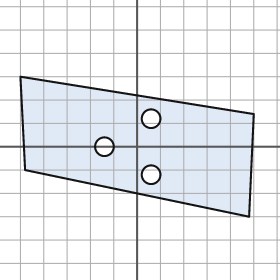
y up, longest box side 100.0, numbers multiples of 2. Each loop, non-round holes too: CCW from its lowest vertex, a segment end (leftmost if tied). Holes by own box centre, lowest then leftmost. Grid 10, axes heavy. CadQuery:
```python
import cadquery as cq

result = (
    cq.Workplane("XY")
    .moveTo(48.0, -30.0)
    .lineTo(50.0, 14.0)
    .lineTo(-50.0, 30.0)
    .lineTo(-48.0, -10.0)
    .close()
    .moveTo(6.0, -12.0)
    .circle(4.0)
    .moveTo(-14.0, 0.0)
    .circle(4.0)
    .moveTo(6.0, 12.0)
    .circle(4.0)
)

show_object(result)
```